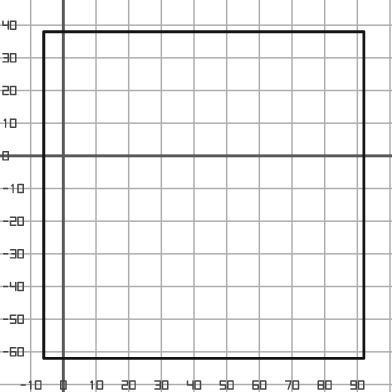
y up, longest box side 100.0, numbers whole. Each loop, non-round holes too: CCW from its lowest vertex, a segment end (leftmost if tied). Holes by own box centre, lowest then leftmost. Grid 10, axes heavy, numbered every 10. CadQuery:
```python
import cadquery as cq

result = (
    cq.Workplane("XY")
    .moveTo(-6.0, -62.0)
    .lineTo(92.0, -62.0)
    .lineTo(92.0, 38.0)
    .lineTo(-6.0, 38.0)
    .close()
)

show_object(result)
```